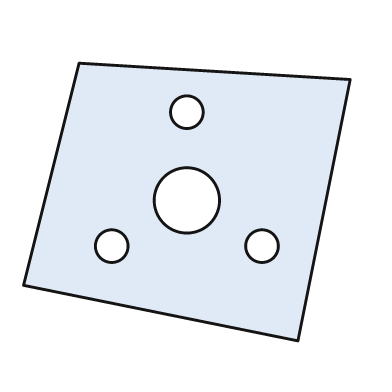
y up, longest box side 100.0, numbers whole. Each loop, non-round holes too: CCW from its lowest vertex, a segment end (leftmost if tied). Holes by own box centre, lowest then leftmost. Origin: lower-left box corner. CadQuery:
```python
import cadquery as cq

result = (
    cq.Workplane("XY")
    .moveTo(84.0, 0.0)
    .lineTo(100.0, 80.0)
    .lineTo(17.0, 85.0)
    .lineTo(0.0, 17.0)
    .close()
    .moveTo(27.0, 29.0)
    .circle(5.0)
    .moveTo(73.0, 29.0)
    .circle(5.0)
    .moveTo(50.0, 43.0)
    .circle(10.0)
    .moveTo(50.0, 70.0)
    .circle(5.0)
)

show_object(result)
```